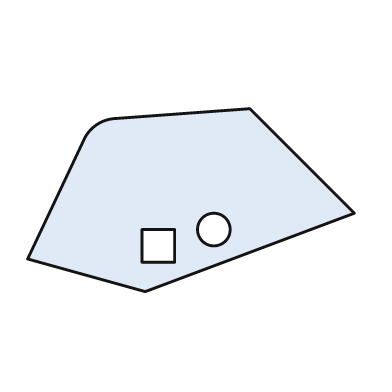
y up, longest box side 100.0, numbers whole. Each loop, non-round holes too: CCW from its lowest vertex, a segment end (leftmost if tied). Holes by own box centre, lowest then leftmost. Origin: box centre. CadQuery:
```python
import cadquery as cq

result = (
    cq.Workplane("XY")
    .moveTo(-14.0, -28.0)
    .lineTo(50.0, -4.0)
    .lineTo(18.0, 28.0)
    .lineTo(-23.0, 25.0)
    .threePointArc((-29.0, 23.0), (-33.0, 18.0))
    .lineTo(-50.0, -18.0)
    .close()
    .moveTo(-15.0, -19.0)
    .lineTo(-5.0, -19.0)
    .lineTo(-5.0, -9.0)
    .lineTo(-15.0, -9.0)
    .close()
    .moveTo(7.0, -9.0)
    .circle(5.0)
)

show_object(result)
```